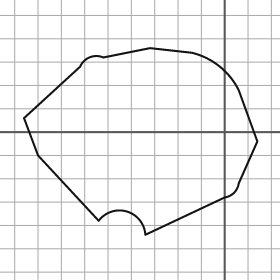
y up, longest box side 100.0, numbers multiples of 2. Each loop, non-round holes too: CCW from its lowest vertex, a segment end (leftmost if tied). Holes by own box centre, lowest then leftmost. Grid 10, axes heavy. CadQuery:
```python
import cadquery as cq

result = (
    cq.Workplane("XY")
    .moveTo(-34.0, -44.0)
    .lineTo(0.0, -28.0)
    .threePointArc((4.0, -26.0), (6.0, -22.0))
    .lineTo(14.0, -4.0)
    .lineTo(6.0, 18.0)
    .threePointArc((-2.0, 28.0), (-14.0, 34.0))
    .lineTo(-32.0, 36.0)
    .lineTo(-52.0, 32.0)
    .threePointArc((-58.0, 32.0), (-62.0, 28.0))
    .lineTo(-86.0, 6.0)
    .lineTo(-80.0, -10.0)
    .lineTo(-54.0, -38.0)
    .threePointArc((-42.0, -34.0), (-34.0, -44.0))
    .close()
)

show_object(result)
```